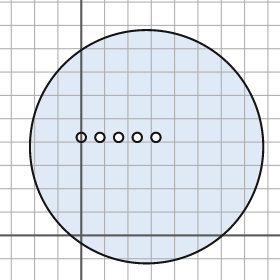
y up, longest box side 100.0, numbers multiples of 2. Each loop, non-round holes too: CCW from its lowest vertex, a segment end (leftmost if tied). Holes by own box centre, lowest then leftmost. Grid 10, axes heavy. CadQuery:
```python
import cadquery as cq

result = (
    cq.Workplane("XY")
    .moveTo(28.0, 38.0)
    .circle(50.0)
    .moveTo(0.0, 42.0)
    .circle(2.0)
    .moveTo(8.0, 42.0)
    .circle(2.0)
    .moveTo(16.0, 42.0)
    .circle(2.0)
    .moveTo(24.0, 42.0)
    .circle(2.0)
    .moveTo(32.0, 42.0)
    .circle(2.0)
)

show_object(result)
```